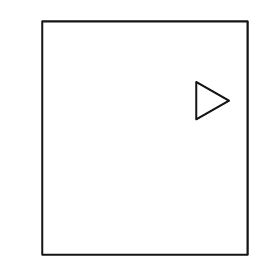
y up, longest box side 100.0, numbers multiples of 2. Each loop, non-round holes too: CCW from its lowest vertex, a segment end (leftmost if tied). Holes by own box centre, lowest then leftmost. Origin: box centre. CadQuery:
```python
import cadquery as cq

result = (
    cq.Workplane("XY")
    .moveTo(-44.0, -50.0)
    .lineTo(44.0, -50.0)
    .lineTo(44.0, 50.0)
    .lineTo(-44.0, 50.0)
    .close()
    .moveTo(22.0, 8.0)
    .lineTo(36.0, 16.0)
    .lineTo(22.0, 24.0)
    .close()
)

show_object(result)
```